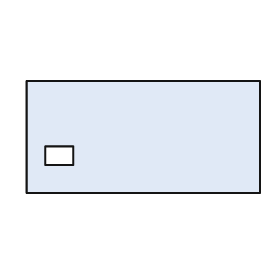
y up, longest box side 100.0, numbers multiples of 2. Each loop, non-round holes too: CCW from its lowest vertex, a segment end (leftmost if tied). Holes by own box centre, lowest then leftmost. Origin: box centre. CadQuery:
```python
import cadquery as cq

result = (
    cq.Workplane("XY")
    .moveTo(-50.0, -24.0)
    .lineTo(50.0, -24.0)
    .lineTo(50.0, 24.0)
    .lineTo(-50.0, 24.0)
    .close()
    .moveTo(-42.0, -12.0)
    .lineTo(-30.0, -12.0)
    .lineTo(-30.0, -4.0)
    .lineTo(-42.0, -4.0)
    .close()
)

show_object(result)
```